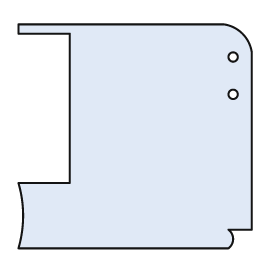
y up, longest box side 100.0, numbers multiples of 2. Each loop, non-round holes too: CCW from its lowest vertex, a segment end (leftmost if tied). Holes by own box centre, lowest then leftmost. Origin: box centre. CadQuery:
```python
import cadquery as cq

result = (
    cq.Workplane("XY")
    .moveTo(-50.0, -48.0)
    .lineTo(40.0, -48.0)
    .threePointArc((42.0, -44.0), (40.0, -40.0))
    .lineTo(50.0, -40.0)
    .lineTo(50.0, 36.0)
    .threePointArc((46.0, 44.0), (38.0, 48.0))
    .lineTo(-50.0, 48.0)
    .lineTo(-50.0, 44.0)
    .lineTo(-28.0, 44.0)
    .lineTo(-28.0, -20.0)
    .lineTo(-50.0, -20.0)
    .threePointArc((-48.0, -34.0), (-50.0, -48.0))
    .close()
    .moveTo(42.0, 18.0)
    .circle(2.0)
    .moveTo(42.0, 34.0)
    .circle(2.0)
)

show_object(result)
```